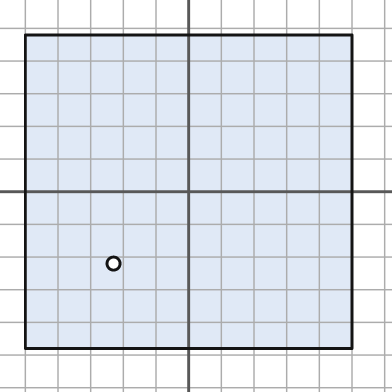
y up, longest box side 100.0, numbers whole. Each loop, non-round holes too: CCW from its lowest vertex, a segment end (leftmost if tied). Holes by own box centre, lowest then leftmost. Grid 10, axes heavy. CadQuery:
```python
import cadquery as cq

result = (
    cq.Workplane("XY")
    .moveTo(-50.0, -48.0)
    .lineTo(50.0, -48.0)
    .lineTo(50.0, 48.0)
    .lineTo(-50.0, 48.0)
    .close()
    .moveTo(-23.0, -22.0)
    .circle(2.0)
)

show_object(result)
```